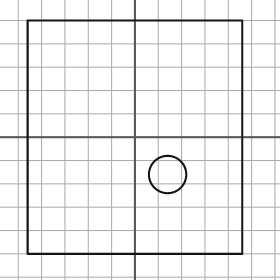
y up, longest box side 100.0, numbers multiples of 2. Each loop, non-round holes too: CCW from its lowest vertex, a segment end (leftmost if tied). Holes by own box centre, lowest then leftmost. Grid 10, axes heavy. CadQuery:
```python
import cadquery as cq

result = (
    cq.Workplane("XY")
    .moveTo(-46.0, -50.0)
    .lineTo(46.0, -50.0)
    .lineTo(46.0, 50.0)
    .lineTo(-46.0, 50.0)
    .close()
    .moveTo(14.0, -16.0)
    .circle(8.0)
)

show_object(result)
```